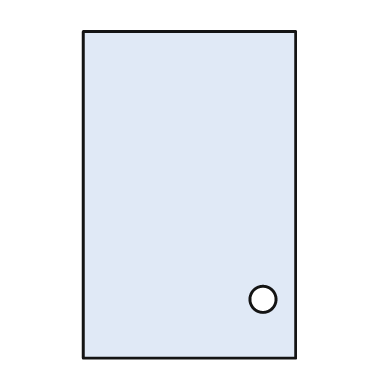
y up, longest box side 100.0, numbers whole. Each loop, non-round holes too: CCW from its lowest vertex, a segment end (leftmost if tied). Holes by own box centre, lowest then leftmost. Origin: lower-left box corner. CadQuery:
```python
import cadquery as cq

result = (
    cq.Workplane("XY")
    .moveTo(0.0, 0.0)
    .lineTo(65.0, 0.0)
    .lineTo(65.0, 100.0)
    .lineTo(0.0, 100.0)
    .close()
    .moveTo(55.0, 18.0)
    .circle(4.0)
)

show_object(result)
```